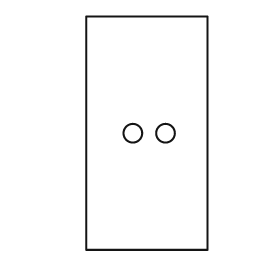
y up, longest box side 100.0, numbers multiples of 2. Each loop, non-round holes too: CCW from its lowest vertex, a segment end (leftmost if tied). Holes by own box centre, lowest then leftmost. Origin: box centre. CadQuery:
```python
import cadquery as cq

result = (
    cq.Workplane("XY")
    .moveTo(-26.0, -50.0)
    .lineTo(26.0, -50.0)
    .lineTo(26.0, 50.0)
    .lineTo(-26.0, 50.0)
    .close()
    .moveTo(-6.0, 0.0)
    .circle(4.0)
    .moveTo(8.0, 0.0)
    .circle(4.0)
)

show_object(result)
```